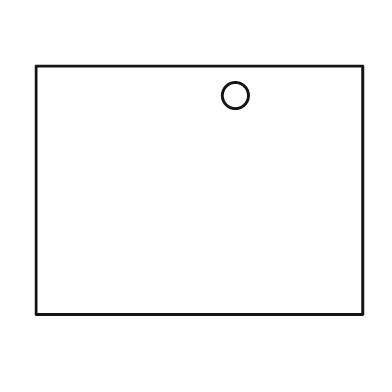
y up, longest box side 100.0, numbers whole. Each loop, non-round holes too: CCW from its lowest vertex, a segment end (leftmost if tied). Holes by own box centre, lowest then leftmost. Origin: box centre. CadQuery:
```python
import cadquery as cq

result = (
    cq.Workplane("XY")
    .moveTo(-50.0, -38.0)
    .lineTo(50.0, -38.0)
    .lineTo(50.0, 38.0)
    .lineTo(-50.0, 38.0)
    .close()
    .moveTo(11.0, 29.0)
    .circle(4.0)
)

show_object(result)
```